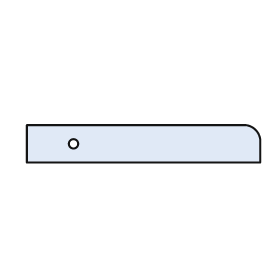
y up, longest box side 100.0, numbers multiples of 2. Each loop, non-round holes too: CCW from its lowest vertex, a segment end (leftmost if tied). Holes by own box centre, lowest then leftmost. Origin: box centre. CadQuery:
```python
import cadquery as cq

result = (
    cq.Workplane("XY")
    .moveTo(-50.0, -8.0)
    .lineTo(50.0, -8.0)
    .lineTo(50.0, 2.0)
    .threePointArc((48.0, 6.0), (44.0, 8.0))
    .lineTo(-50.0, 8.0)
    .close()
    .moveTo(-30.0, 0.0)
    .circle(2.0)
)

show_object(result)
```